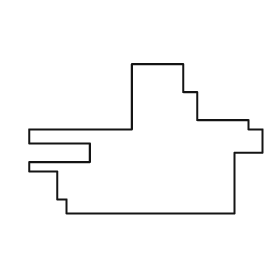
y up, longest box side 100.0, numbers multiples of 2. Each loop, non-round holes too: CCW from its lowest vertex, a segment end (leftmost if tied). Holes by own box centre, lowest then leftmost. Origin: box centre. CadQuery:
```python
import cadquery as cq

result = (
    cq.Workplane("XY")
    .moveTo(-34.0, -32.0)
    .lineTo(38.0, -32.0)
    .lineTo(38.0, -6.0)
    .lineTo(50.0, -6.0)
    .lineTo(50.0, 4.0)
    .lineTo(44.0, 4.0)
    .lineTo(44.0, 8.0)
    .lineTo(22.0, 8.0)
    .lineTo(22.0, 20.0)
    .lineTo(16.0, 20.0)
    .lineTo(16.0, 32.0)
    .lineTo(-6.0, 32.0)
    .lineTo(-6.0, 4.0)
    .lineTo(-50.0, 4.0)
    .lineTo(-50.0, -2.0)
    .lineTo(-24.0, -2.0)
    .lineTo(-24.0, -10.0)
    .lineTo(-50.0, -10.0)
    .lineTo(-50.0, -14.0)
    .lineTo(-38.0, -14.0)
    .lineTo(-38.0, -26.0)
    .lineTo(-34.0, -26.0)
    .close()
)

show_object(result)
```